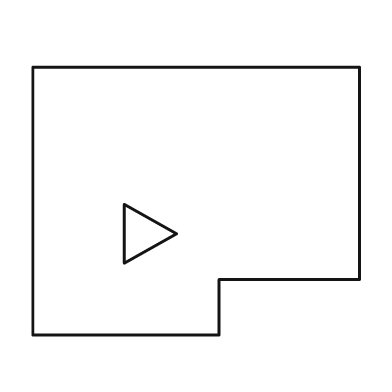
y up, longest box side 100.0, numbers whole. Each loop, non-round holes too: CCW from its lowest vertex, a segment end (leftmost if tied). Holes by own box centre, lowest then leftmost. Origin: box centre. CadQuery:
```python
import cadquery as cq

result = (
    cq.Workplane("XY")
    .moveTo(-50.0, -41.0)
    .lineTo(7.0, -41.0)
    .lineTo(7.0, -24.0)
    .lineTo(50.0, -24.0)
    .lineTo(50.0, 41.0)
    .lineTo(-50.0, 41.0)
    .close()
    .moveTo(-22.0, -19.0)
    .lineTo(-6.0, -10.0)
    .lineTo(-22.0, -1.0)
    .close()
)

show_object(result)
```